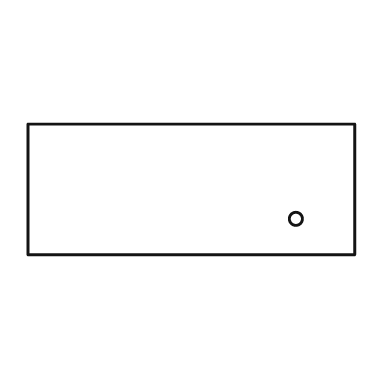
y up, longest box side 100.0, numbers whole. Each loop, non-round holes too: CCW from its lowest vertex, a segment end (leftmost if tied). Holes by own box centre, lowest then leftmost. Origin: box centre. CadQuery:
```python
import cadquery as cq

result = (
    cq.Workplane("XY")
    .moveTo(-50.0, -20.0)
    .lineTo(50.0, -20.0)
    .lineTo(50.0, 20.0)
    .lineTo(-50.0, 20.0)
    .close()
    .moveTo(32.0, -9.0)
    .circle(2.0)
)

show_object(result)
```